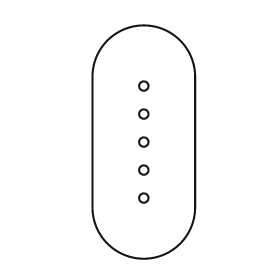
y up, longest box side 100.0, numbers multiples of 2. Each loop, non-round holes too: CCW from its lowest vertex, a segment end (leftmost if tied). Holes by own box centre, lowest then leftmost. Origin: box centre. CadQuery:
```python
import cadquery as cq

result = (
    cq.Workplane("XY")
    .moveTo(-22.0, -28.0)
    .threePointArc((0.0, -50.0), (22.0, -28.0))
    .lineTo(22.0, 28.0)
    .threePointArc((0.0, 50.0), (-22.0, 28.0))
    .close()
    .moveTo(0.0, -24.0)
    .circle(2.0)
    .moveTo(0.0, -12.0)
    .circle(2.0)
    .moveTo(0.0, 0.0)
    .circle(2.0)
    .moveTo(0.0, 12.0)
    .circle(2.0)
    .moveTo(0.0, 24.0)
    .circle(2.0)
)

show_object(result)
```